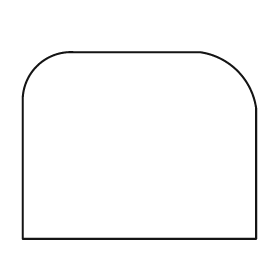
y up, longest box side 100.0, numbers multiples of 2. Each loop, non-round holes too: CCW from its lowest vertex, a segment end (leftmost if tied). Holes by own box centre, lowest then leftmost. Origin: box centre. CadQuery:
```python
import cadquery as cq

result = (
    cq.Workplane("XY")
    .moveTo(-50.0, -40.0)
    .lineTo(50.0, -40.0)
    .lineTo(50.0, 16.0)
    .threePointArc((42.0, 32.0), (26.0, 40.0))
    .lineTo(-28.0, 40.0)
    .threePointArc((-44.0, 34.0), (-50.0, 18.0))
    .close()
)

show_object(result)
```